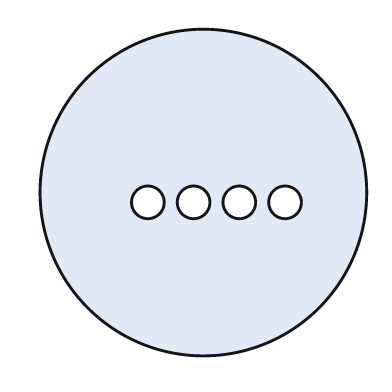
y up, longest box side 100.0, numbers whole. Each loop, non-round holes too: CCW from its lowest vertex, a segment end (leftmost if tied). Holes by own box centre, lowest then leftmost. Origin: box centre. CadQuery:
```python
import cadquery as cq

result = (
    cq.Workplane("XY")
    .moveTo(0.0, 0.0)
    .circle(50.0)
    .moveTo(-17.0, -3.0)
    .circle(5.0)
    .moveTo(-3.0, -3.0)
    .circle(5.0)
    .moveTo(11.0, -3.0)
    .circle(5.0)
    .moveTo(25.0, -3.0)
    .circle(5.0)
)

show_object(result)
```